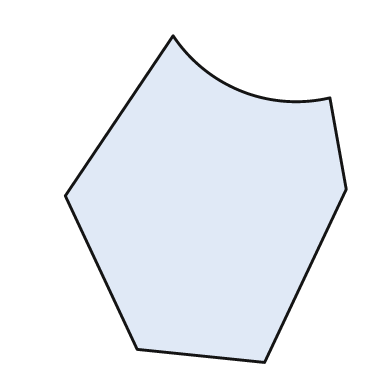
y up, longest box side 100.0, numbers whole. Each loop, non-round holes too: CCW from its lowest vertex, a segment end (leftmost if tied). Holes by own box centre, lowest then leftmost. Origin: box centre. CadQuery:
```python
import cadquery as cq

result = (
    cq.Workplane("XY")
    .moveTo(18.0, -50.0)
    .lineTo(43.0, 3.0)
    .lineTo(38.0, 31.0)
    .threePointArc((11.0, 33.0), (-10.0, 50.0))
    .lineTo(-43.0, 1.0)
    .lineTo(-21.0, -46.0)
    .close()
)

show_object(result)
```